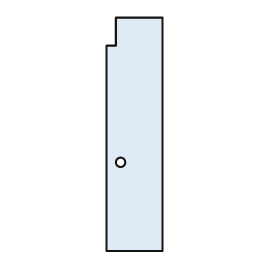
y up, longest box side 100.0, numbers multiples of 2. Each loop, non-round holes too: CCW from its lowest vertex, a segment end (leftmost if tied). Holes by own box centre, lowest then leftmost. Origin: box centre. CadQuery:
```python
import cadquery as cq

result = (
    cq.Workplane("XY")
    .moveTo(-12.0, -50.0)
    .lineTo(12.0, -50.0)
    .lineTo(12.0, 50.0)
    .lineTo(-8.0, 50.0)
    .lineTo(-8.0, 38.0)
    .lineTo(-12.0, 38.0)
    .close()
    .moveTo(-6.0, -12.0)
    .circle(2.0)
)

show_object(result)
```